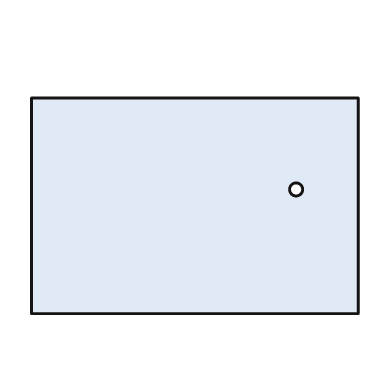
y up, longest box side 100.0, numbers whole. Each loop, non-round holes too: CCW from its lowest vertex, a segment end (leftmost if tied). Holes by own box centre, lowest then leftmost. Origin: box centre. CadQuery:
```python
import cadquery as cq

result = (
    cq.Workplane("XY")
    .moveTo(-50.0, -33.0)
    .lineTo(50.0, -33.0)
    .lineTo(50.0, 33.0)
    .lineTo(-50.0, 33.0)
    .close()
    .moveTo(31.0, 5.0)
    .circle(2.0)
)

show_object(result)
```